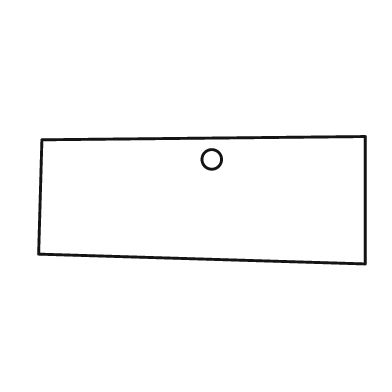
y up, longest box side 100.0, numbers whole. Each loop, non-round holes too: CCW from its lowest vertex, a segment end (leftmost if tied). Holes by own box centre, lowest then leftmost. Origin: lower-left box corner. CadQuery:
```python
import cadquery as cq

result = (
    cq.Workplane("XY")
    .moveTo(100.0, 0.0)
    .lineTo(100.0, 39.0)
    .lineTo(1.0, 38.0)
    .lineTo(0.0, 3.0)
    .close()
    .moveTo(53.0, 32.0)
    .circle(3.0)
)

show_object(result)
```